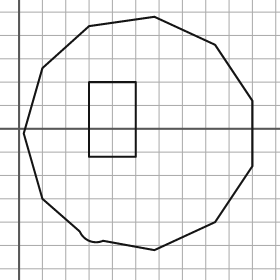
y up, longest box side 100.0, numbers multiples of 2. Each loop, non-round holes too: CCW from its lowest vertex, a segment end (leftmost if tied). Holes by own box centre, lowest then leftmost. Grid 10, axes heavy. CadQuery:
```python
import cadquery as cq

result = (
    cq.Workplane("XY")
    .moveTo(58.0, -52.0)
    .lineTo(84.0, -40.0)
    .lineTo(100.0, -16.0)
    .lineTo(100.0, 12.0)
    .lineTo(84.0, 36.0)
    .lineTo(58.0, 48.0)
    .lineTo(30.0, 44.0)
    .lineTo(10.0, 26.0)
    .lineTo(2.0, -2.0)
    .lineTo(10.0, -30.0)
    .lineTo(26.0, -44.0)
    .threePointArc((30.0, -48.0), (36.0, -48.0))
    .close()
    .moveTo(30.0, -12.0)
    .lineTo(50.0, -12.0)
    .lineTo(50.0, 20.0)
    .lineTo(30.0, 20.0)
    .close()
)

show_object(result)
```